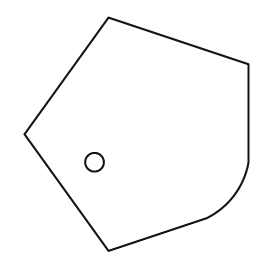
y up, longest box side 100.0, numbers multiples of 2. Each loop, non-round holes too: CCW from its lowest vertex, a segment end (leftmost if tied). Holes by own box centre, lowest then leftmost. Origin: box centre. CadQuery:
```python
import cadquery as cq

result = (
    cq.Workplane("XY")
    .moveTo(-12.0, -50.0)
    .lineTo(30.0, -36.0)
    .threePointArc((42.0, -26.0), (48.0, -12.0))
    .lineTo(48.0, 30.0)
    .lineTo(-12.0, 50.0)
    .lineTo(-48.0, 0.0)
    .close()
    .moveTo(-18.0, -12.0)
    .circle(4.0)
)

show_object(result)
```